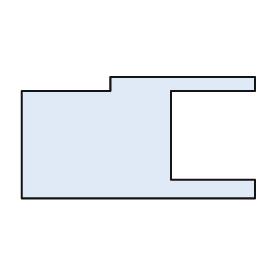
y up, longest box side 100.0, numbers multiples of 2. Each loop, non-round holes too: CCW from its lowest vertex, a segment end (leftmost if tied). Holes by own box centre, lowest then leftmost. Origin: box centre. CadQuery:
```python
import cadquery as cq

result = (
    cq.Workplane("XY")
    .moveTo(-50.0, -26.0)
    .lineTo(50.0, -26.0)
    .lineTo(50.0, -18.0)
    .lineTo(14.0, -18.0)
    .lineTo(14.0, 20.0)
    .lineTo(50.0, 20.0)
    .lineTo(50.0, 26.0)
    .lineTo(-12.0, 26.0)
    .lineTo(-12.0, 20.0)
    .lineTo(-50.0, 20.0)
    .close()
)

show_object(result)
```